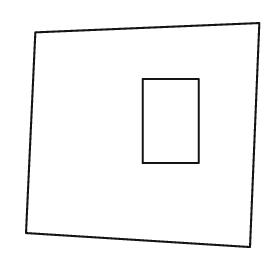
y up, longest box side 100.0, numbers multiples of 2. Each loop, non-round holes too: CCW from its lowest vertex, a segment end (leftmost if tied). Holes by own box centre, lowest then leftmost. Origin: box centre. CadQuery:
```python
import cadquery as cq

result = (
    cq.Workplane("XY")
    .moveTo(46.0, -48.0)
    .lineTo(50.0, 48.0)
    .lineTo(-46.0, 44.0)
    .lineTo(-50.0, -42.0)
    .close()
    .moveTo(0.0, -12.0)
    .lineTo(24.0, -12.0)
    .lineTo(24.0, 24.0)
    .lineTo(0.0, 24.0)
    .close()
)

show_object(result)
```